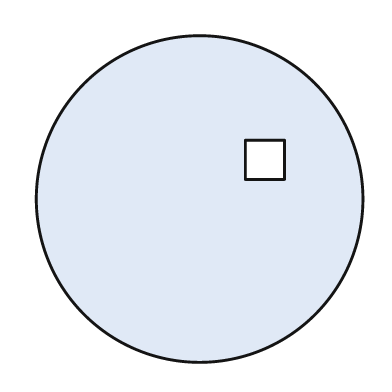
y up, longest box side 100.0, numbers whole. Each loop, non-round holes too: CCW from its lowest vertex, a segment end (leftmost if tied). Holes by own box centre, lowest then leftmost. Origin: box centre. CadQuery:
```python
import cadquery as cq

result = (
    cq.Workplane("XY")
    .moveTo(0.0, 0.0)
    .circle(50.0)
    .moveTo(14.0, 6.0)
    .lineTo(26.0, 6.0)
    .lineTo(26.0, 18.0)
    .lineTo(14.0, 18.0)
    .close()
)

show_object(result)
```